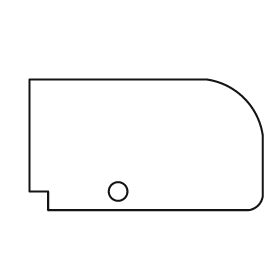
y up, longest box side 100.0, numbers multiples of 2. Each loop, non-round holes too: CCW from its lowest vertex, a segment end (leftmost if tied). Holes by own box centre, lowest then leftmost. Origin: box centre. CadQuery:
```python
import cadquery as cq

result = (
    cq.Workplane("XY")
    .moveTo(-42.0, -28.0)
    .lineTo(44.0, -28.0)
    .threePointArc((48.0, -26.0), (50.0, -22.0))
    .lineTo(50.0, 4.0)
    .threePointArc((42.0, 20.0), (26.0, 28.0))
    .lineTo(-50.0, 28.0)
    .lineTo(-50.0, -20.0)
    .lineTo(-42.0, -20.0)
    .close()
    .moveTo(-12.0, -20.0)
    .circle(4.0)
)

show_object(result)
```